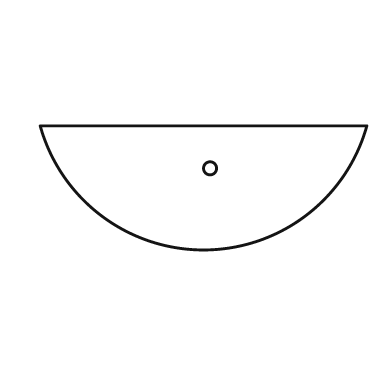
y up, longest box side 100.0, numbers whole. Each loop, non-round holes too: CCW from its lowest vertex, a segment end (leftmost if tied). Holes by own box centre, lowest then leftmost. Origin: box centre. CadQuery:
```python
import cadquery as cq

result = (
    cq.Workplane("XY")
    .moveTo(-50.0, 19.0)
    .threePointArc((0.0, -19.0), (50.0, 19.0))
    .close()
    .moveTo(2.0, 6.0)
    .circle(2.0)
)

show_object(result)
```